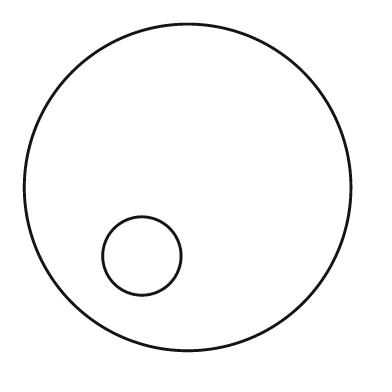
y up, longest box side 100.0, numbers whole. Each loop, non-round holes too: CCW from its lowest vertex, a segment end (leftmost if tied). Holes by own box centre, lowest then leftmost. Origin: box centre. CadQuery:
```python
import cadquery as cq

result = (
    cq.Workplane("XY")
    .moveTo(0.0, 0.0)
    .circle(50.0)
    .moveTo(-14.0, -21.0)
    .circle(12.0)
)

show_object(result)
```